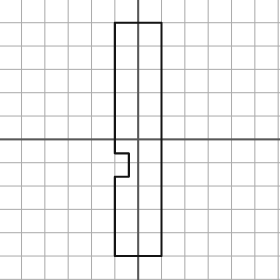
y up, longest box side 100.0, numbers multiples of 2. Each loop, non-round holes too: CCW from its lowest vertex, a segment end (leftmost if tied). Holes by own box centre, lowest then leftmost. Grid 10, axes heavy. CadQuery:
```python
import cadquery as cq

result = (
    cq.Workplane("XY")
    .moveTo(-10.0, -50.0)
    .lineTo(10.0, -50.0)
    .lineTo(10.0, 50.0)
    .lineTo(-10.0, 50.0)
    .lineTo(-10.0, -6.0)
    .lineTo(-4.0, -6.0)
    .lineTo(-4.0, -16.0)
    .lineTo(-10.0, -16.0)
    .close()
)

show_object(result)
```